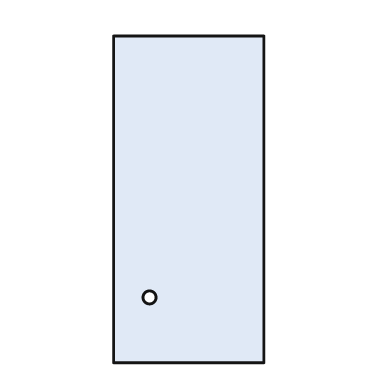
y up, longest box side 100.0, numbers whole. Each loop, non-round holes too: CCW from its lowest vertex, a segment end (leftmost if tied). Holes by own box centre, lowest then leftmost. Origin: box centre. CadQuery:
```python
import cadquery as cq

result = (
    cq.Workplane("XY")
    .moveTo(-23.0, -50.0)
    .lineTo(23.0, -50.0)
    .lineTo(23.0, 50.0)
    .lineTo(-23.0, 50.0)
    .close()
    .moveTo(-12.0, -30.0)
    .circle(2.0)
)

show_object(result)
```